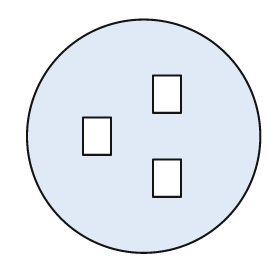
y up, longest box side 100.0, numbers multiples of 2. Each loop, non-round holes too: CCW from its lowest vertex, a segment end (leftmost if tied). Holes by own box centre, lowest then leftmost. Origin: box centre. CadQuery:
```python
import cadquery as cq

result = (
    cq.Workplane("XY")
    .moveTo(0.0, 0.0)
    .circle(50.0)
    .moveTo(4.0, -26.0)
    .lineTo(16.0, -26.0)
    .lineTo(16.0, -10.0)
    .lineTo(4.0, -10.0)
    .close()
    .moveTo(-26.0, -8.0)
    .lineTo(-14.0, -8.0)
    .lineTo(-14.0, 8.0)
    .lineTo(-26.0, 8.0)
    .close()
    .moveTo(4.0, 10.0)
    .lineTo(16.0, 10.0)
    .lineTo(16.0, 26.0)
    .lineTo(4.0, 26.0)
    .close()
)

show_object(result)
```